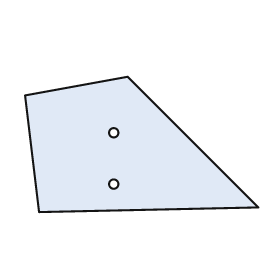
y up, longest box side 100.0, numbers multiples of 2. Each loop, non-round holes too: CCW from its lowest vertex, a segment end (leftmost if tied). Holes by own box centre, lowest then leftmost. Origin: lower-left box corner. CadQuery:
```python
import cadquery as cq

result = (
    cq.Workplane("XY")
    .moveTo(6.0, 0.0)
    .lineTo(100.0, 2.0)
    .lineTo(44.0, 58.0)
    .lineTo(0.0, 50.0)
    .close()
    .moveTo(38.0, 12.0)
    .circle(2.0)
    .moveTo(38.0, 34.0)
    .circle(2.0)
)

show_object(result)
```